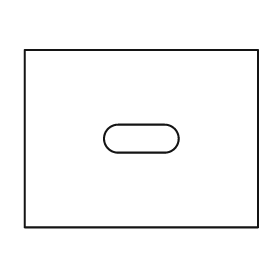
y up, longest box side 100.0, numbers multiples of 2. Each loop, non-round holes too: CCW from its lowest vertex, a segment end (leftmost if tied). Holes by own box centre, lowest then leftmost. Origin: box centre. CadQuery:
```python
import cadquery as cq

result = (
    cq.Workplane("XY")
    .moveTo(-50.0, -38.0)
    .lineTo(50.0, -38.0)
    .lineTo(50.0, 38.0)
    .lineTo(-50.0, 38.0)
    .close()
    .moveTo(-10.0, -6.0)
    .lineTo(10.0, -6.0)
    .threePointArc((16.0, 0.0), (10.0, 6.0))
    .lineTo(-10.0, 6.0)
    .threePointArc((-16.0, 0.0), (-10.0, -6.0))
    .close()
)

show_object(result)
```